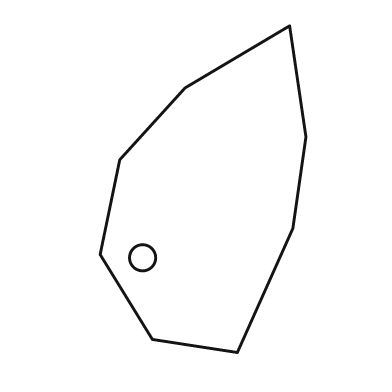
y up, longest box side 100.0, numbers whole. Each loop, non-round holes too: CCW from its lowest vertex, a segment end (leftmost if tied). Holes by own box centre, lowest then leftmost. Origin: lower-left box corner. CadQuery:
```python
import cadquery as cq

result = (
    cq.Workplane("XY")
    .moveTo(42.0, 0.0)
    .lineTo(59.0, 38.0)
    .lineTo(63.0, 66.0)
    .lineTo(58.0, 100.0)
    .lineTo(26.0, 81.0)
    .lineTo(6.0, 59.0)
    .lineTo(0.0, 30.0)
    .lineTo(16.0, 4.0)
    .close()
    .moveTo(13.0, 29.0)
    .circle(4.0)
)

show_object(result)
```